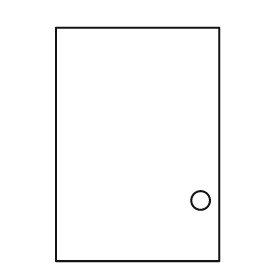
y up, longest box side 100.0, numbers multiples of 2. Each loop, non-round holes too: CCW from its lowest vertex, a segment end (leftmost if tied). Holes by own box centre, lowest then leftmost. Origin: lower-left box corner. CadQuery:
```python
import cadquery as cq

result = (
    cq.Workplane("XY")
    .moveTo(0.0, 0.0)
    .lineTo(70.0, 0.0)
    .lineTo(70.0, 100.0)
    .lineTo(0.0, 100.0)
    .close()
    .moveTo(62.0, 26.0)
    .circle(4.0)
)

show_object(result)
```